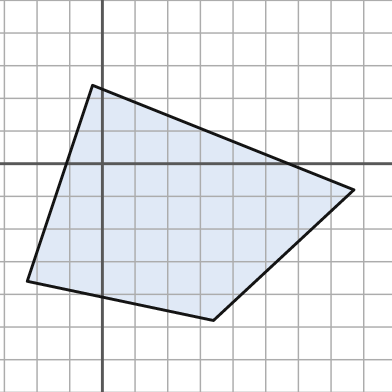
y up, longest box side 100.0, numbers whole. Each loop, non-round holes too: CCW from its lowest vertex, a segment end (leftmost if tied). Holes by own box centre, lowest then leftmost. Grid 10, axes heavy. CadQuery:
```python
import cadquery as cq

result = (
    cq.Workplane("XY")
    .moveTo(34.0, -48.0)
    .lineTo(77.0, -8.0)
    .lineTo(-3.0, 24.0)
    .lineTo(-23.0, -36.0)
    .close()
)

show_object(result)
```